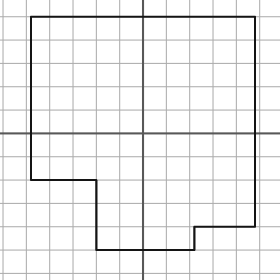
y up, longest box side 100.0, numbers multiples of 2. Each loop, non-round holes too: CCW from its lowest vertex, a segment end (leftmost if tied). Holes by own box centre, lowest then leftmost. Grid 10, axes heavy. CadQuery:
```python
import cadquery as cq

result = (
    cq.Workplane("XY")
    .moveTo(-20.0, -50.0)
    .lineTo(22.0, -50.0)
    .lineTo(22.0, -40.0)
    .lineTo(48.0, -40.0)
    .lineTo(48.0, 50.0)
    .lineTo(-48.0, 50.0)
    .lineTo(-48.0, -20.0)
    .lineTo(-20.0, -20.0)
    .close()
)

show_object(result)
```